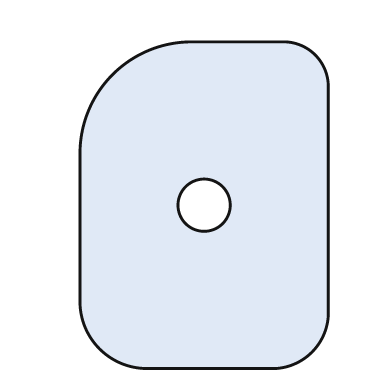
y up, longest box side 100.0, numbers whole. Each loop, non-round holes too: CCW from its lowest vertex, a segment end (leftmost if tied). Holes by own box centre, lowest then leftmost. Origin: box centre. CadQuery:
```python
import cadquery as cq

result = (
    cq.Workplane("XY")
    .moveTo(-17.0, -50.0)
    .lineTo(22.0, -50.0)
    .threePointArc((33.0, -45.0), (38.0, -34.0))
    .lineTo(38.0, 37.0)
    .threePointArc((34.0, 46.0), (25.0, 50.0))
    .lineTo(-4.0, 50.0)
    .threePointArc((-28.0, 40.0), (-38.0, 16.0))
    .lineTo(-38.0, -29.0)
    .threePointArc((-32.0, -44.0), (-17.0, -50.0))
    .close()
    .moveTo(0.0, 0.0)
    .circle(8.0)
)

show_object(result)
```